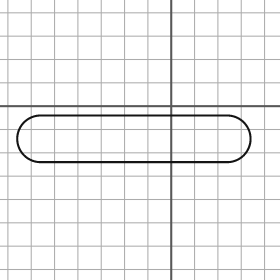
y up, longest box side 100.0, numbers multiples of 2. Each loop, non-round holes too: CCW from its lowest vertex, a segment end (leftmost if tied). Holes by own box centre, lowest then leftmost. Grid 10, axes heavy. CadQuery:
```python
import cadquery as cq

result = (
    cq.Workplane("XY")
    .moveTo(-56.0, -24.0)
    .lineTo(24.0, -24.0)
    .threePointArc((34.0, -14.0), (24.0, -4.0))
    .lineTo(-56.0, -4.0)
    .threePointArc((-66.0, -14.0), (-56.0, -24.0))
    .close()
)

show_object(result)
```